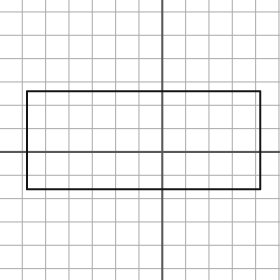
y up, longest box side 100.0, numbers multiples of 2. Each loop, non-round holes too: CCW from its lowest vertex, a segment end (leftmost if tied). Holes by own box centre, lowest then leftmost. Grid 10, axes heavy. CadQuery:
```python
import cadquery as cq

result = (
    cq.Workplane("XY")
    .moveTo(-58.0, -16.0)
    .lineTo(42.0, -16.0)
    .lineTo(42.0, 26.0)
    .lineTo(-58.0, 26.0)
    .close()
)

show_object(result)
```